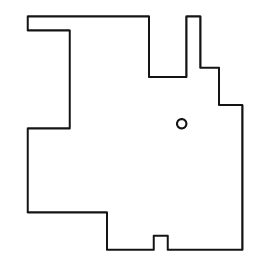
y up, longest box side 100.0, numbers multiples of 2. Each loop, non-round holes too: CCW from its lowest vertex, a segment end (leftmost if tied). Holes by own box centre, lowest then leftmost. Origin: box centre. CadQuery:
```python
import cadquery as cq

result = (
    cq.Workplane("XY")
    .moveTo(-12.0, -50.0)
    .lineTo(8.0, -50.0)
    .lineTo(8.0, -44.0)
    .lineTo(14.0, -44.0)
    .lineTo(14.0, -50.0)
    .lineTo(46.0, -50.0)
    .lineTo(46.0, 12.0)
    .lineTo(36.0, 12.0)
    .lineTo(36.0, 28.0)
    .lineTo(28.0, 28.0)
    .lineTo(28.0, 50.0)
    .lineTo(22.0, 50.0)
    .lineTo(22.0, 24.0)
    .lineTo(6.0, 24.0)
    .lineTo(6.0, 50.0)
    .lineTo(-46.0, 50.0)
    .lineTo(-46.0, 44.0)
    .lineTo(-28.0, 44.0)
    .lineTo(-28.0, 2.0)
    .lineTo(-46.0, 2.0)
    .lineTo(-46.0, -34.0)
    .lineTo(-12.0, -34.0)
    .close()
    .moveTo(20.0, 4.0)
    .circle(2.0)
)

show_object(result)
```